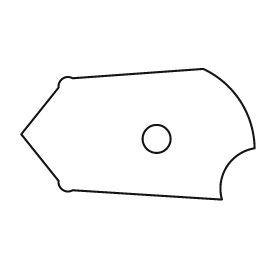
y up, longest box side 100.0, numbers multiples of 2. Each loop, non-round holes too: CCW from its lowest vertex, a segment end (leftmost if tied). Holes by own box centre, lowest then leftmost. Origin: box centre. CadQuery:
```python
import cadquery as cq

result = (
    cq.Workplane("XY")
    .moveTo(36.0, -28.0)
    .threePointArc((38.0, -14.0), (50.0, -6.0))
    .threePointArc((44.0, 14.0), (28.0, 28.0))
    .lineTo(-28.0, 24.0)
    .threePointArc((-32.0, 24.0), (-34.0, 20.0))
    .lineTo(-50.0, 0.0)
    .lineTo(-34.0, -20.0)
    .threePointArc((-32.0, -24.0), (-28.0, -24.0))
    .close()
    .moveTo(8.0, -2.0)
    .circle(6.0)
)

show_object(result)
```